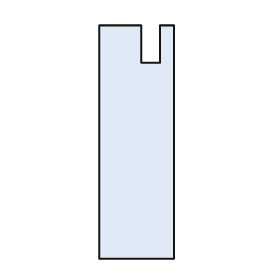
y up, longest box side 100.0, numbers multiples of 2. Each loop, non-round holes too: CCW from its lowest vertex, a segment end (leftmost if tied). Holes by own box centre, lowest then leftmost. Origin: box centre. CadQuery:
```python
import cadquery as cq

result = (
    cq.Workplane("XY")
    .moveTo(-16.0, -50.0)
    .lineTo(16.0, -50.0)
    .lineTo(16.0, 50.0)
    .lineTo(10.0, 50.0)
    .lineTo(10.0, 34.0)
    .lineTo(2.0, 34.0)
    .lineTo(2.0, 50.0)
    .lineTo(-16.0, 50.0)
    .close()
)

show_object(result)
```